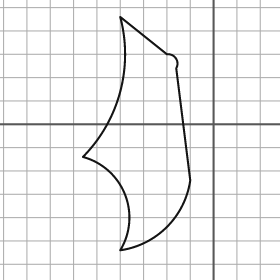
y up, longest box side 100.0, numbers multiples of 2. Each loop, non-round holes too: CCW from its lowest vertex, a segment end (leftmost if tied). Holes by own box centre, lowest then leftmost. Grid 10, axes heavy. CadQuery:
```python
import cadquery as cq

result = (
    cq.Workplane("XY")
    .moveTo(-40.0, -54.0)
    .threePointArc((-20.0, -44.0), (-10.0, -24.0))
    .lineTo(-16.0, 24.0)
    .threePointArc((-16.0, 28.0), (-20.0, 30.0))
    .lineTo(-40.0, 46.0)
    .threePointArc((-40.0, 14.0), (-56.0, -14.0))
    .threePointArc((-38.0, -30.0), (-40.0, -54.0))
    .close()
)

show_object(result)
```